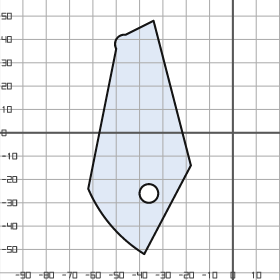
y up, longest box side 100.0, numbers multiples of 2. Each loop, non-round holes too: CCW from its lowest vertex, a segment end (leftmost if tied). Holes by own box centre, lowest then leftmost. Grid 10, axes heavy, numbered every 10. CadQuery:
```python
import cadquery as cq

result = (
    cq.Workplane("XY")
    .moveTo(-38.0, -52.0)
    .lineTo(-18.0, -14.0)
    .lineTo(-34.0, 48.0)
    .lineTo(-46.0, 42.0)
    .threePointArc((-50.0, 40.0), (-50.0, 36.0))
    .lineTo(-62.0, -24.0)
    .threePointArc((-52.0, -40.0), (-38.0, -52.0))
    .close()
    .moveTo(-36.0, -26.0)
    .circle(4.0)
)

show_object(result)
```